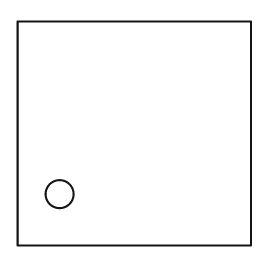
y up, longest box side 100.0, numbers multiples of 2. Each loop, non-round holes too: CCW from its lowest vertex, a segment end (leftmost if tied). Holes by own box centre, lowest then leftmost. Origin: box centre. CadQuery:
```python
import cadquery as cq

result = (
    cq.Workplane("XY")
    .moveTo(-50.0, -48.0)
    .lineTo(50.0, -48.0)
    .lineTo(50.0, 48.0)
    .lineTo(-50.0, 48.0)
    .close()
    .moveTo(-32.0, -26.0)
    .circle(6.0)
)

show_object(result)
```